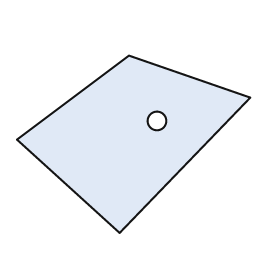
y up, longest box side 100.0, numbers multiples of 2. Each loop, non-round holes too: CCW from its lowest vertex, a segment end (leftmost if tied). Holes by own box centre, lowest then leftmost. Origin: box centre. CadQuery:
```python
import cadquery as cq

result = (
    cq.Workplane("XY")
    .moveTo(-6.0, -38.0)
    .lineTo(50.0, 20.0)
    .lineTo(-2.0, 38.0)
    .lineTo(-50.0, 2.0)
    .close()
    .moveTo(10.0, 10.0)
    .circle(4.0)
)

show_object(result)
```